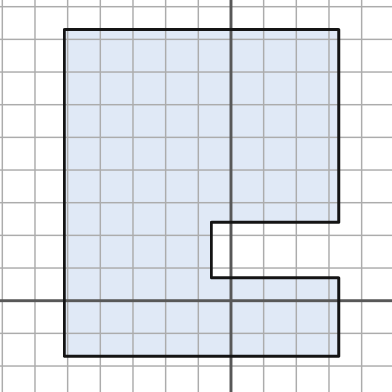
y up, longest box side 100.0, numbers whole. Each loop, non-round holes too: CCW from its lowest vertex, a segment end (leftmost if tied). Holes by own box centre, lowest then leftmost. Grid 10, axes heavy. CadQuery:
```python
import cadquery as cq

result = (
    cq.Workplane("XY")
    .moveTo(-51.0, -17.0)
    .lineTo(33.0, -17.0)
    .lineTo(33.0, 7.0)
    .lineTo(-6.0, 7.0)
    .lineTo(-6.0, 24.0)
    .lineTo(33.0, 24.0)
    .lineTo(33.0, 83.0)
    .lineTo(-51.0, 83.0)
    .close()
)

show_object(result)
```